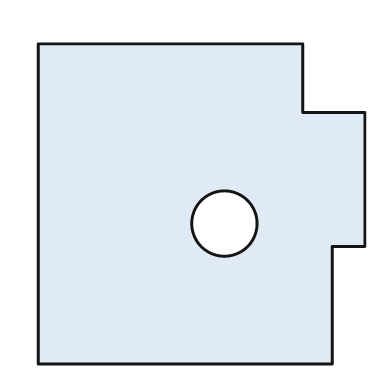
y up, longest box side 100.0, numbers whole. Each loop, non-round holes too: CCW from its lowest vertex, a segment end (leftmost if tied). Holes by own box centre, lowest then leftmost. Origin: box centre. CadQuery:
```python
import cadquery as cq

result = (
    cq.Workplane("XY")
    .moveTo(-50.0, -49.0)
    .lineTo(40.0, -49.0)
    .lineTo(40.0, -13.0)
    .lineTo(50.0, -13.0)
    .lineTo(50.0, 28.0)
    .lineTo(31.0, 28.0)
    .lineTo(31.0, 49.0)
    .lineTo(-50.0, 49.0)
    .close()
    .moveTo(7.0, -6.0)
    .circle(10.0)
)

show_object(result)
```